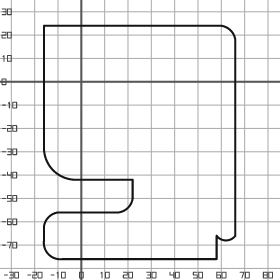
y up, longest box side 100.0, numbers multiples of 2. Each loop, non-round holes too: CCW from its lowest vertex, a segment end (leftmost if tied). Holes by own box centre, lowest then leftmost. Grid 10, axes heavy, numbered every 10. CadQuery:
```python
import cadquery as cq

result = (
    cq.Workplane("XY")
    .moveTo(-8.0, -76.0)
    .lineTo(58.0, -76.0)
    .lineTo(58.0, -66.0)
    .threePointArc((62.0, -68.0), (66.0, -66.0))
    .lineTo(66.0, 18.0)
    .threePointArc((64.0, 22.0), (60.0, 24.0))
    .lineTo(-16.0, 24.0)
    .lineTo(-16.0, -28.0)
    .threePointArc((-12.0, -38.0), (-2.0, -42.0))
    .lineTo(22.0, -42.0)
    .lineTo(22.0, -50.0)
    .threePointArc((20.0, -54.0), (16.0, -56.0))
    .lineTo(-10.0, -56.0)
    .threePointArc((-14.0, -58.0), (-16.0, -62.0))
    .lineTo(-16.0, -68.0)
    .threePointArc((-14.0, -74.0), (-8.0, -76.0))
    .close()
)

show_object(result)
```